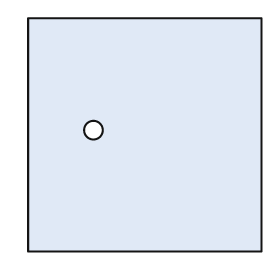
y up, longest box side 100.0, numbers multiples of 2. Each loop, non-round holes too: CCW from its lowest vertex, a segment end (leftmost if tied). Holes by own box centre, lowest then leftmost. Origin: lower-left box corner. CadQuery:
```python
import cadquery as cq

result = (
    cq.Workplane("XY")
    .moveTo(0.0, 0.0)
    .lineTo(100.0, 0.0)
    .lineTo(100.0, 100.0)
    .lineTo(0.0, 100.0)
    .close()
    .moveTo(28.0, 52.0)
    .circle(4.0)
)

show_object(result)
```